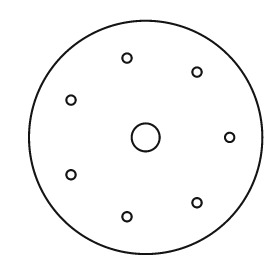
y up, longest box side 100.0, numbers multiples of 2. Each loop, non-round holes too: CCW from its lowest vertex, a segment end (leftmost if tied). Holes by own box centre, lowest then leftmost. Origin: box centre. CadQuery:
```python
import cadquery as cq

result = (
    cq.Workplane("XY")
    .moveTo(0.0, 0.0)
    .circle(50.0)
    .moveTo(-8.0, -34.0)
    .circle(2.0)
    .moveTo(22.0, -28.0)
    .circle(2.0)
    .moveTo(-32.0, -16.0)
    .circle(2.0)
    .moveTo(0.0, 0.0)
    .circle(6.0)
    .moveTo(36.0, 0.0)
    .circle(2.0)
    .moveTo(-32.0, 16.0)
    .circle(2.0)
    .moveTo(22.0, 28.0)
    .circle(2.0)
    .moveTo(-8.0, 34.0)
    .circle(2.0)
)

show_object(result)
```